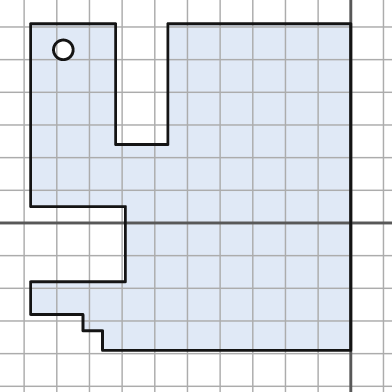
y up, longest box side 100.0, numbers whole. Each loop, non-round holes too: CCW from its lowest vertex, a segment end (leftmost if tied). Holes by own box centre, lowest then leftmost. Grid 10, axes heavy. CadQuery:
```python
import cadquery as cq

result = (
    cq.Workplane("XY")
    .moveTo(-76.0, -39.0)
    .lineTo(0.0, -39.0)
    .lineTo(0.0, 61.0)
    .lineTo(-56.0, 61.0)
    .lineTo(-56.0, 24.0)
    .lineTo(-72.0, 24.0)
    .lineTo(-72.0, 61.0)
    .lineTo(-98.0, 61.0)
    .lineTo(-98.0, 5.0)
    .lineTo(-69.0, 5.0)
    .lineTo(-69.0, -18.0)
    .lineTo(-98.0, -18.0)
    .lineTo(-98.0, -28.0)
    .lineTo(-82.0, -28.0)
    .lineTo(-82.0, -33.0)
    .lineTo(-76.0, -33.0)
    .close()
    .moveTo(-88.0, 53.0)
    .circle(3.0)
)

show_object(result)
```